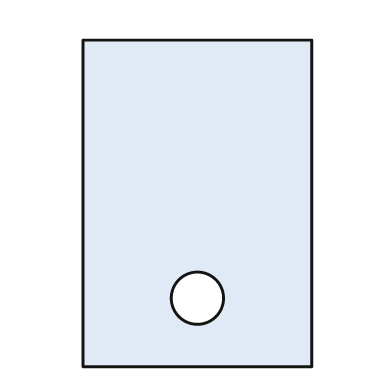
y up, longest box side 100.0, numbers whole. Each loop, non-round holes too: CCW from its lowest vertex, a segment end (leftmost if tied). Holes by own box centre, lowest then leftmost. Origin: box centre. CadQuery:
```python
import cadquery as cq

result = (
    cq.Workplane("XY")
    .moveTo(-35.0, -50.0)
    .lineTo(35.0, -50.0)
    .lineTo(35.0, 50.0)
    .lineTo(-35.0, 50.0)
    .close()
    .moveTo(0.0, -29.0)
    .circle(8.0)
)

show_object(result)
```